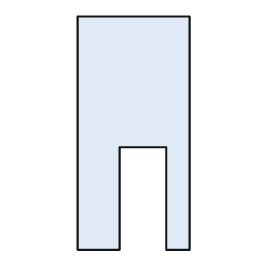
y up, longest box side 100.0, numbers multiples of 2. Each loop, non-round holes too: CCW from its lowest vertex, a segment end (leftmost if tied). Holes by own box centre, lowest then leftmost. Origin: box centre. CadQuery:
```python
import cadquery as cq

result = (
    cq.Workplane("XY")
    .moveTo(-24.0, -50.0)
    .lineTo(-6.0, -50.0)
    .lineTo(-6.0, -6.0)
    .lineTo(14.0, -6.0)
    .lineTo(14.0, -50.0)
    .lineTo(24.0, -50.0)
    .lineTo(24.0, 50.0)
    .lineTo(-24.0, 50.0)
    .close()
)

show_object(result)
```